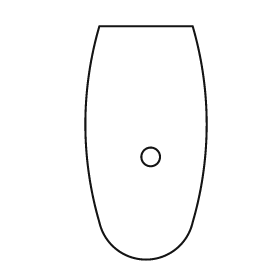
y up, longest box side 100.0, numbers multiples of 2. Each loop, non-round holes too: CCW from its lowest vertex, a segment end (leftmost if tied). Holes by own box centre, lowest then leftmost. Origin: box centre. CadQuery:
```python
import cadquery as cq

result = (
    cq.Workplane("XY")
    .moveTo(-20.0, -34.0)
    .threePointArc((0.0, -50.0), (20.0, -34.0))
    .threePointArc((26.0, 8.0), (20.0, 50.0))
    .lineTo(-20.0, 50.0)
    .threePointArc((-26.0, 8.0), (-20.0, -34.0))
    .close()
    .moveTo(2.0, -6.0)
    .circle(4.0)
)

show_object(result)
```